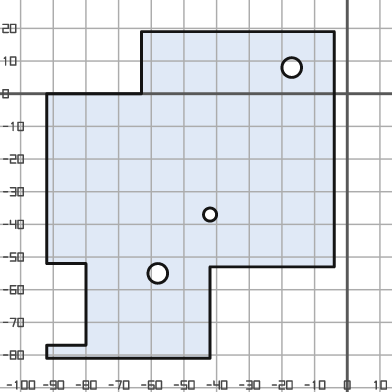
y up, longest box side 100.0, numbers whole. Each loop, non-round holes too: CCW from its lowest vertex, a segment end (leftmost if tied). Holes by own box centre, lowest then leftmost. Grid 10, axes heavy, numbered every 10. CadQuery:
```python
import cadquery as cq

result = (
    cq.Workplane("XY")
    .moveTo(-92.0, -81.0)
    .lineTo(-42.0, -81.0)
    .lineTo(-42.0, -53.0)
    .lineTo(-4.0, -53.0)
    .lineTo(-4.0, 19.0)
    .lineTo(-63.0, 19.0)
    .lineTo(-63.0, 0.0)
    .lineTo(-92.0, 0.0)
    .lineTo(-92.0, -52.0)
    .lineTo(-80.0, -52.0)
    .lineTo(-80.0, -77.0)
    .lineTo(-92.0, -77.0)
    .close()
    .moveTo(-58.0, -55.0)
    .circle(3.0)
    .moveTo(-42.0, -37.0)
    .circle(2.0)
    .moveTo(-17.0, 8.0)
    .circle(3.0)
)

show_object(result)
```